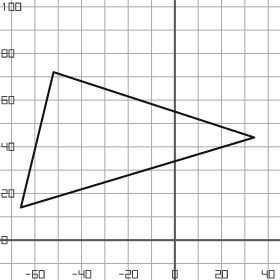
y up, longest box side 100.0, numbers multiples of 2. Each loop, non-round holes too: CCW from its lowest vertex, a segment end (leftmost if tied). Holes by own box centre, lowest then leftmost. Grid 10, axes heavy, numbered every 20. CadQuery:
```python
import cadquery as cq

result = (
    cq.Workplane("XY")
    .moveTo(-66.0, 14.0)
    .lineTo(34.0, 44.0)
    .lineTo(-52.0, 72.0)
    .close()
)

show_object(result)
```